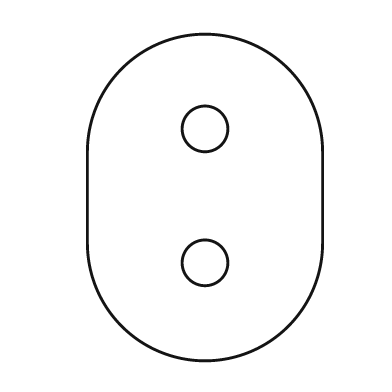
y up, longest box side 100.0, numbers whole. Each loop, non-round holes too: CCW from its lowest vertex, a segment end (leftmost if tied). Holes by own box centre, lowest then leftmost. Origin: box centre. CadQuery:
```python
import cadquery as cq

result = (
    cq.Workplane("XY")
    .moveTo(-36.0, -14.0)
    .threePointArc((0.0, -50.0), (36.0, -14.0))
    .lineTo(36.0, 14.0)
    .threePointArc((0.0, 50.0), (-36.0, 14.0))
    .close()
    .moveTo(0.0, -20.0)
    .circle(7.0)
    .moveTo(0.0, 21.0)
    .circle(7.0)
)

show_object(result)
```